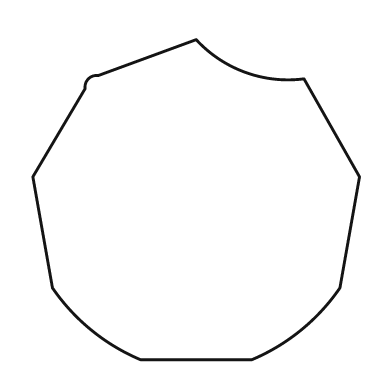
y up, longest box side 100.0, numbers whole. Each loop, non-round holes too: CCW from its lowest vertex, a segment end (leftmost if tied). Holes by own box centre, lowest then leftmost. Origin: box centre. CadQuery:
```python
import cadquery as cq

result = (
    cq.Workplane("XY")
    .moveTo(-17.0, -49.0)
    .lineTo(17.0, -49.0)
    .threePointArc((32.0, -40.0), (44.0, -27.0))
    .lineTo(50.0, 7.0)
    .lineTo(33.0, 37.0)
    .threePointArc((15.0, 39.0), (0.0, 49.0))
    .lineTo(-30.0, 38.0)
    .threePointArc((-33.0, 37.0), (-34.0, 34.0))
    .lineTo(-50.0, 7.0)
    .lineTo(-44.0, -27.0)
    .threePointArc((-32.0, -40.0), (-17.0, -49.0))
    .close()
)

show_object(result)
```